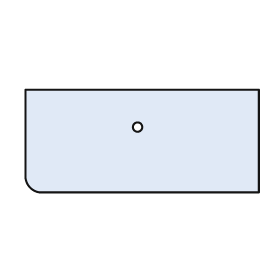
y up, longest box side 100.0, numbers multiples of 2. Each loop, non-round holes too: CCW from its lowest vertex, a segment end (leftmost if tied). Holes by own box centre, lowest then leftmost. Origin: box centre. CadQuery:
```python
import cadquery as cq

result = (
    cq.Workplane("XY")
    .moveTo(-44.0, -22.0)
    .lineTo(50.0, -22.0)
    .lineTo(50.0, 22.0)
    .lineTo(-50.0, 22.0)
    .lineTo(-50.0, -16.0)
    .threePointArc((-48.0, -20.0), (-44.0, -22.0))
    .close()
    .moveTo(-2.0, 6.0)
    .circle(2.0)
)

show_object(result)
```